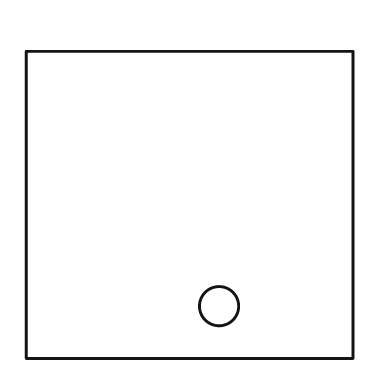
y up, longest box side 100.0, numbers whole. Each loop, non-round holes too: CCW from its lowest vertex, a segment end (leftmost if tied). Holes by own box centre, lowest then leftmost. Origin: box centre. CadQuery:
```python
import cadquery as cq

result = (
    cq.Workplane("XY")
    .moveTo(-50.0, -47.0)
    .lineTo(50.0, -47.0)
    .lineTo(50.0, 47.0)
    .lineTo(-50.0, 47.0)
    .close()
    .moveTo(9.0, -31.0)
    .circle(6.0)
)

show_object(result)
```